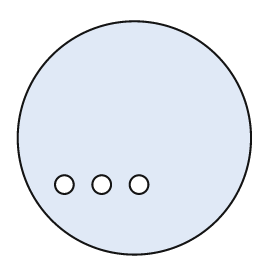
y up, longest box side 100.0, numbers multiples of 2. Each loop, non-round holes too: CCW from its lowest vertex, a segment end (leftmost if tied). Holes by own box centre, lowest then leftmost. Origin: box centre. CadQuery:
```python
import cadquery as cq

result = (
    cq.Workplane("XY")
    .moveTo(0.0, 0.0)
    .circle(50.0)
    .moveTo(-30.0, -20.0)
    .circle(4.0)
    .moveTo(-14.0, -20.0)
    .circle(4.0)
    .moveTo(2.0, -20.0)
    .circle(4.0)
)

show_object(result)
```